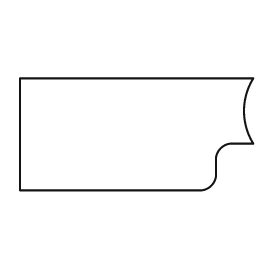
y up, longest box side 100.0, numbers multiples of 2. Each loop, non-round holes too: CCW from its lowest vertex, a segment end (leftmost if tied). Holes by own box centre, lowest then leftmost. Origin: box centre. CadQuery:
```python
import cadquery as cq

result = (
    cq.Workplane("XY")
    .moveTo(-50.0, -24.0)
    .lineTo(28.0, -24.0)
    .threePointArc((32.0, -22.0), (34.0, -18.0))
    .lineTo(34.0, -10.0)
    .threePointArc((36.0, -6.0), (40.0, -4.0))
    .lineTo(50.0, -4.0)
    .threePointArc((46.0, 10.0), (50.0, 24.0))
    .lineTo(-50.0, 24.0)
    .close()
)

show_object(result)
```